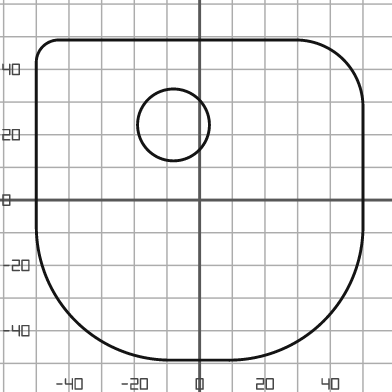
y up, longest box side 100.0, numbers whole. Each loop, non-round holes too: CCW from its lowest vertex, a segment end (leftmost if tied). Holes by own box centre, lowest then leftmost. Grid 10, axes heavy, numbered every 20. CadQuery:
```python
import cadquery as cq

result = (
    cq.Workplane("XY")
    .moveTo(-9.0, -49.0)
    .lineTo(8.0, -49.0)
    .threePointArc((38.0, -37.0), (50.0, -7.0))
    .lineTo(50.0, 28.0)
    .threePointArc((44.0, 43.0), (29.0, 49.0))
    .lineTo(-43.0, 49.0)
    .threePointArc((-48.0, 47.0), (-50.0, 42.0))
    .lineTo(-50.0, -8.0)
    .threePointArc((-38.0, -37.0), (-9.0, -49.0))
    .close()
    .moveTo(-8.0, 23.0)
    .circle(11.0)
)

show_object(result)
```